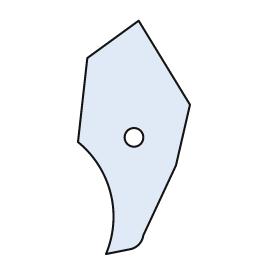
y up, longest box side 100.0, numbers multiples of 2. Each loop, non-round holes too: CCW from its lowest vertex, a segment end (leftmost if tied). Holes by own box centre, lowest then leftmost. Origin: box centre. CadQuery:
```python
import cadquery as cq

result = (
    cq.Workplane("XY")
    .moveTo(-12.0, -50.0)
    .lineTo(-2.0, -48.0)
    .threePointArc((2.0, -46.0), (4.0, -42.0))
    .lineTo(18.0, -12.0)
    .lineTo(24.0, 14.0)
    .lineTo(2.0, 50.0)
    .lineTo(-20.0, 34.0)
    .lineTo(-24.0, -2.0)
    .threePointArc((-10.0, -24.0), (-12.0, -50.0))
    .close()
    .moveTo(0.0, 0.0)
    .circle(4.0)
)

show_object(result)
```